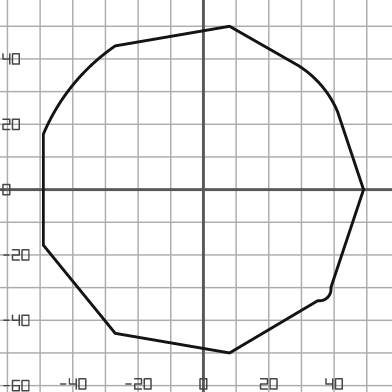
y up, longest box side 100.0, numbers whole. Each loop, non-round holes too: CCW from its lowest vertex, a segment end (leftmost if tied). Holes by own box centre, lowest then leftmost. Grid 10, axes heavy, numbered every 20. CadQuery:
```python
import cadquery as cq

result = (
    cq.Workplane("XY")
    .moveTo(8.0, -50.0)
    .lineTo(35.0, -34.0)
    .threePointArc((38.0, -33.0), (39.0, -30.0))
    .lineTo(49.0, 0.0)
    .lineTo(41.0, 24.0)
    .threePointArc((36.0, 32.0), (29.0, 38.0))
    .lineTo(8.0, 50.0)
    .lineTo(-27.0, 44.0)
    .threePointArc((-40.0, 32.0), (-49.0, 17.0))
    .lineTo(-49.0, -17.0)
    .lineTo(-27.0, -44.0)
    .close()
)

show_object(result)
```